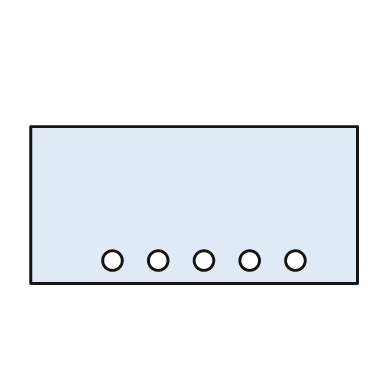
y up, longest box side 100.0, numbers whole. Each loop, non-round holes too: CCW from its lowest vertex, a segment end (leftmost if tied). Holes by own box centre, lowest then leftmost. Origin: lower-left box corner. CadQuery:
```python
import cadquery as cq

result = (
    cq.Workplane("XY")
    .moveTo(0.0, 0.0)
    .lineTo(100.0, 0.0)
    .lineTo(100.0, 48.0)
    .lineTo(0.0, 48.0)
    .close()
    .moveTo(25.0, 7.0)
    .circle(3.0)
    .moveTo(39.0, 7.0)
    .circle(3.0)
    .moveTo(53.0, 7.0)
    .circle(3.0)
    .moveTo(67.0, 7.0)
    .circle(3.0)
    .moveTo(81.0, 7.0)
    .circle(3.0)
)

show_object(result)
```